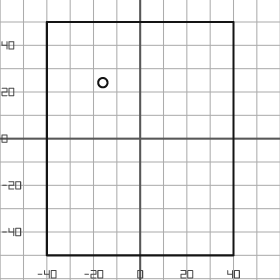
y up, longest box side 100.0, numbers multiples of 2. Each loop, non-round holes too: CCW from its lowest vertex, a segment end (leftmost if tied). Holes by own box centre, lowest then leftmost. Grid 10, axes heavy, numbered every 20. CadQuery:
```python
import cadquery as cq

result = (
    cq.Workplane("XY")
    .moveTo(-40.0, -50.0)
    .lineTo(40.0, -50.0)
    .lineTo(40.0, 50.0)
    .lineTo(-40.0, 50.0)
    .close()
    .moveTo(-16.0, 24.0)
    .circle(2.0)
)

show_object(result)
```